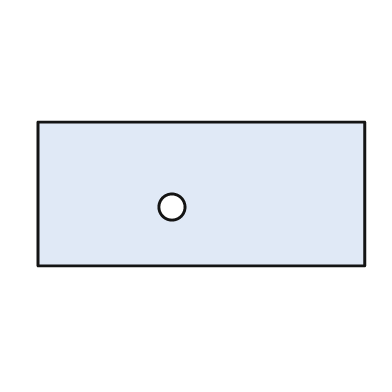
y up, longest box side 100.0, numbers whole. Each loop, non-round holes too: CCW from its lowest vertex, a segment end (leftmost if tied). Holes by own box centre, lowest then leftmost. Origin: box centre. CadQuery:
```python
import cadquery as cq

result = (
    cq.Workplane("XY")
    .moveTo(-50.0, -22.0)
    .lineTo(50.0, -22.0)
    .lineTo(50.0, 22.0)
    .lineTo(-50.0, 22.0)
    .close()
    .moveTo(-9.0, -4.0)
    .circle(4.0)
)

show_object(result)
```